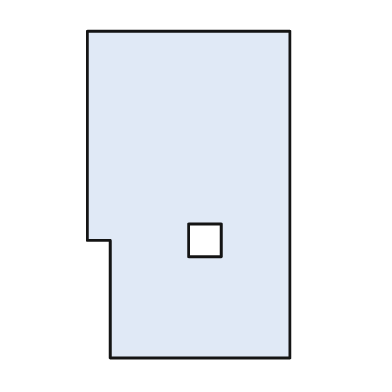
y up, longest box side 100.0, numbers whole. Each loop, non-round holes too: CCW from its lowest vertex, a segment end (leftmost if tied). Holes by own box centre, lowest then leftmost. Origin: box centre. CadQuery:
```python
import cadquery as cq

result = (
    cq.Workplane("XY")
    .moveTo(-24.0, -50.0)
    .lineTo(31.0, -50.0)
    .lineTo(31.0, 50.0)
    .lineTo(-31.0, 50.0)
    .lineTo(-31.0, -14.0)
    .lineTo(-24.0, -14.0)
    .close()
    .moveTo(0.0, -19.0)
    .lineTo(10.0, -19.0)
    .lineTo(10.0, -9.0)
    .lineTo(0.0, -9.0)
    .close()
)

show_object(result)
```